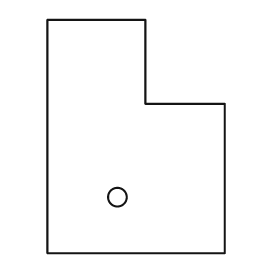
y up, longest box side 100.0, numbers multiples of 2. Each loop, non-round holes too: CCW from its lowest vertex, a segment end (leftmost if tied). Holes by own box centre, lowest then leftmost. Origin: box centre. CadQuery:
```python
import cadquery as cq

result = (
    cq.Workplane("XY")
    .moveTo(-38.0, -50.0)
    .lineTo(38.0, -50.0)
    .lineTo(38.0, 14.0)
    .lineTo(4.0, 14.0)
    .lineTo(4.0, 50.0)
    .lineTo(-38.0, 50.0)
    .close()
    .moveTo(-8.0, -26.0)
    .circle(4.0)
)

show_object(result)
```